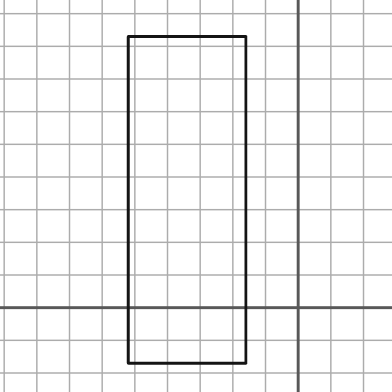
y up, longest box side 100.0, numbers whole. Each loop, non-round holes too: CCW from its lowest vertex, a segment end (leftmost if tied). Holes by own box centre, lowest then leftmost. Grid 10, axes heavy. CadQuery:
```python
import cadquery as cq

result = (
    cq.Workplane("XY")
    .moveTo(-52.0, -17.0)
    .lineTo(-16.0, -17.0)
    .lineTo(-16.0, 83.0)
    .lineTo(-52.0, 83.0)
    .close()
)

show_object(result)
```